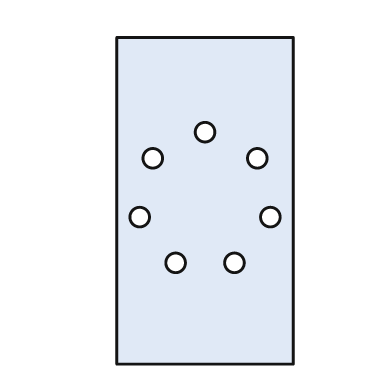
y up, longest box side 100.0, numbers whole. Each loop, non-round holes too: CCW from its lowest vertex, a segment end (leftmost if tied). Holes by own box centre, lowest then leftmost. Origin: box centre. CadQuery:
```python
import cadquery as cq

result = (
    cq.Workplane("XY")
    .moveTo(-27.0, -50.0)
    .lineTo(27.0, -50.0)
    .lineTo(27.0, 50.0)
    .lineTo(-27.0, 50.0)
    .close()
    .moveTo(-9.0, -19.0)
    .circle(3.0)
    .moveTo(9.0, -19.0)
    .circle(3.0)
    .moveTo(-20.0, -5.0)
    .circle(3.0)
    .moveTo(20.0, -5.0)
    .circle(3.0)
    .moveTo(-16.0, 13.0)
    .circle(3.0)
    .moveTo(16.0, 13.0)
    .circle(3.0)
    .moveTo(0.0, 21.0)
    .circle(3.0)
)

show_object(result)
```